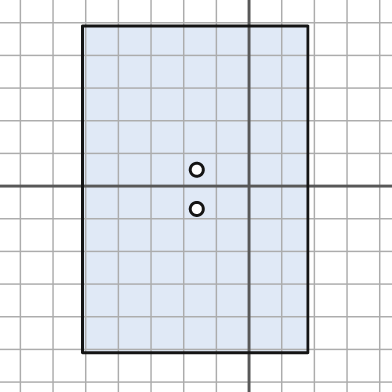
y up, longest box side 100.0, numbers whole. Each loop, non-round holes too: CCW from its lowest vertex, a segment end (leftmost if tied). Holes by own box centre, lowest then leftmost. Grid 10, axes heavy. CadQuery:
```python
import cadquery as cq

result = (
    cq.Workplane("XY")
    .moveTo(-51.0, -51.0)
    .lineTo(18.0, -51.0)
    .lineTo(18.0, 49.0)
    .lineTo(-51.0, 49.0)
    .close()
    .moveTo(-16.0, -7.0)
    .circle(2.0)
    .moveTo(-16.0, 5.0)
    .circle(2.0)
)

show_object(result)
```